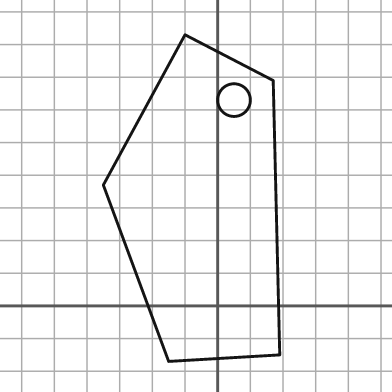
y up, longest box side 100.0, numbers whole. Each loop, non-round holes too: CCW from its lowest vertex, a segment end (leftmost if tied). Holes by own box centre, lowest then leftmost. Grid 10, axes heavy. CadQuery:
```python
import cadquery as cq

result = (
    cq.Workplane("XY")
    .moveTo(-15.0, -17.0)
    .lineTo(19.0, -15.0)
    .lineTo(17.0, 69.0)
    .lineTo(-10.0, 83.0)
    .lineTo(-35.0, 37.0)
    .close()
    .moveTo(5.0, 63.0)
    .circle(5.0)
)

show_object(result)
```